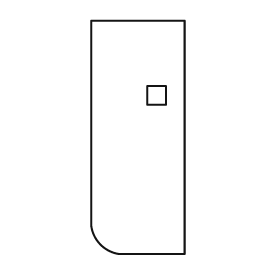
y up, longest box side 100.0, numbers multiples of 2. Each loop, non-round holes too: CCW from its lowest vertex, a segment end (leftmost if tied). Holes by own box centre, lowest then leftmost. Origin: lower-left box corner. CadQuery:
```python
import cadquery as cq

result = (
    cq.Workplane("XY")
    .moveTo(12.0, 0.0)
    .lineTo(40.0, 0.0)
    .lineTo(40.0, 100.0)
    .lineTo(0.0, 100.0)
    .lineTo(0.0, 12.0)
    .threePointArc((4.0, 4.0), (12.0, 0.0))
    .close()
    .moveTo(24.0, 64.0)
    .lineTo(32.0, 64.0)
    .lineTo(32.0, 72.0)
    .lineTo(24.0, 72.0)
    .close()
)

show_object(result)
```